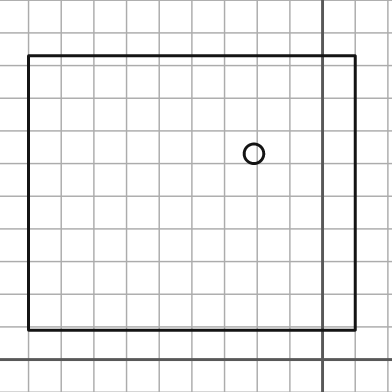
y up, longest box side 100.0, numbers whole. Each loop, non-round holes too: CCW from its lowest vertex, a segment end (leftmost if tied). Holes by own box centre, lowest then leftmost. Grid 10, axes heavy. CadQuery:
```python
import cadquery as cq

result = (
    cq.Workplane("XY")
    .moveTo(-90.0, 9.0)
    .lineTo(10.0, 9.0)
    .lineTo(10.0, 93.0)
    .lineTo(-90.0, 93.0)
    .close()
    .moveTo(-21.0, 63.0)
    .circle(3.0)
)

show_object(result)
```